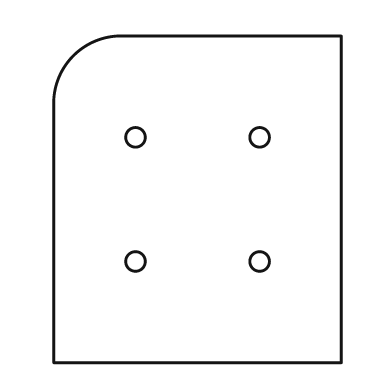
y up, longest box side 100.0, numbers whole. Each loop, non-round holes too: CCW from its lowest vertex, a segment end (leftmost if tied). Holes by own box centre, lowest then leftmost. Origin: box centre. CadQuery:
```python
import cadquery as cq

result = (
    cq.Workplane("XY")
    .moveTo(-44.0, -50.0)
    .lineTo(44.0, -50.0)
    .lineTo(44.0, 50.0)
    .lineTo(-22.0, 50.0)
    .threePointArc((-38.0, 44.0), (-44.0, 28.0))
    .close()
    .moveTo(-19.0, -19.0)
    .circle(3.0)
    .moveTo(19.0, -19.0)
    .circle(3.0)
    .moveTo(-19.0, 19.0)
    .circle(3.0)
    .moveTo(19.0, 19.0)
    .circle(3.0)
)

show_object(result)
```